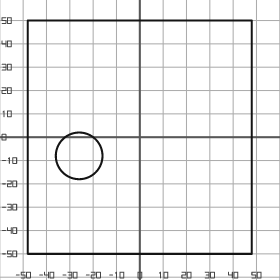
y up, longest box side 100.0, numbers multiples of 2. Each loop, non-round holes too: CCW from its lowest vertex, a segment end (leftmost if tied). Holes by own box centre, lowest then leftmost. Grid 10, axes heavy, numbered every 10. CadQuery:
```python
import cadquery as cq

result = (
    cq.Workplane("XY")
    .moveTo(-48.0, -50.0)
    .lineTo(48.0, -50.0)
    .lineTo(48.0, 50.0)
    .lineTo(-48.0, 50.0)
    .close()
    .moveTo(-26.0, -8.0)
    .circle(10.0)
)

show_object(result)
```